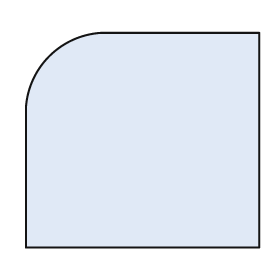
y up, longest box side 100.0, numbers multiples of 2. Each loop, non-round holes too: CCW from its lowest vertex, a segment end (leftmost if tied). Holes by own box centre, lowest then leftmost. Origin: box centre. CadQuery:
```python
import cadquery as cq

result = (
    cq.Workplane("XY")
    .moveTo(-50.0, -46.0)
    .lineTo(50.0, -46.0)
    .lineTo(50.0, 46.0)
    .lineTo(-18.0, 46.0)
    .threePointArc((-40.0, 36.0), (-50.0, 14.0))
    .close()
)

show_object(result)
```